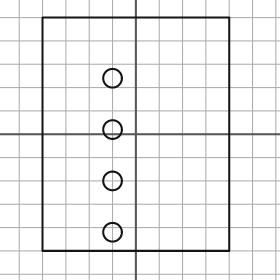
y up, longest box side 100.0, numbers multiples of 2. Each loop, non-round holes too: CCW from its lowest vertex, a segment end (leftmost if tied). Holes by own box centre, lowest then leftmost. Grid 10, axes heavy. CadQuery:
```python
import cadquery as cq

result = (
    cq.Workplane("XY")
    .moveTo(-40.0, -50.0)
    .lineTo(40.0, -50.0)
    .lineTo(40.0, 50.0)
    .lineTo(-40.0, 50.0)
    .close()
    .moveTo(-10.0, -42.0)
    .circle(4.0)
    .moveTo(-10.0, -20.0)
    .circle(4.0)
    .moveTo(-10.0, 2.0)
    .circle(4.0)
    .moveTo(-10.0, 24.0)
    .circle(4.0)
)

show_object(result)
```